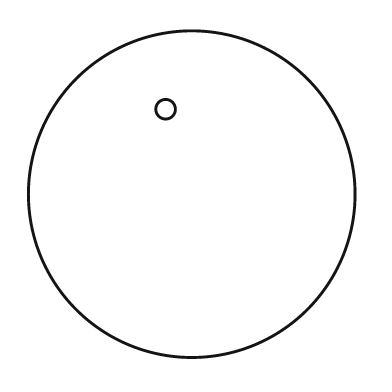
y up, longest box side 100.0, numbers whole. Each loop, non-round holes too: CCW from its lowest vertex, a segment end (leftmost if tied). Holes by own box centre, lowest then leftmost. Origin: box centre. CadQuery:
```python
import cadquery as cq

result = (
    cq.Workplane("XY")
    .moveTo(0.0, 0.0)
    .circle(50.0)
    .moveTo(-8.0, 26.0)
    .circle(3.0)
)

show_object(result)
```